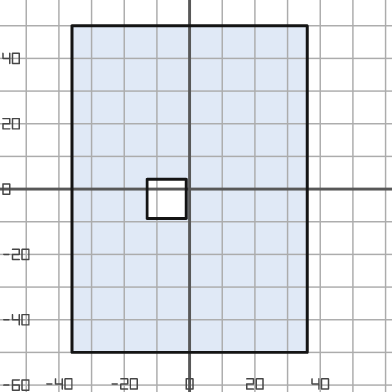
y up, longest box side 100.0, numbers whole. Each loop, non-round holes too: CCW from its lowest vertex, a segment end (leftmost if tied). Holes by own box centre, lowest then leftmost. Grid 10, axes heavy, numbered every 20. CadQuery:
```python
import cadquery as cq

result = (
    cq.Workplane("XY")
    .moveTo(-36.0, -50.0)
    .lineTo(36.0, -50.0)
    .lineTo(36.0, 50.0)
    .lineTo(-36.0, 50.0)
    .close()
    .moveTo(-13.0, -9.0)
    .lineTo(-1.0, -9.0)
    .lineTo(-1.0, 3.0)
    .lineTo(-13.0, 3.0)
    .close()
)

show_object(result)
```